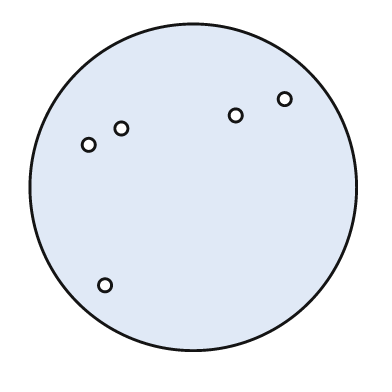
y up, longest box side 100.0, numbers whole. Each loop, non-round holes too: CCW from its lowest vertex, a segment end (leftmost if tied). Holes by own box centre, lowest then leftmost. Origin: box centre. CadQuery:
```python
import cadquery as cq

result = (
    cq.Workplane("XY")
    .moveTo(0.0, 0.0)
    .circle(50.0)
    .moveTo(-27.0, -30.0)
    .circle(2.0)
    .moveTo(-32.0, 13.0)
    .circle(2.0)
    .moveTo(-22.0, 18.0)
    .circle(2.0)
    .moveTo(13.0, 22.0)
    .circle(2.0)
    .moveTo(28.0, 27.0)
    .circle(2.0)
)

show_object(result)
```